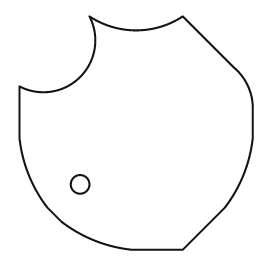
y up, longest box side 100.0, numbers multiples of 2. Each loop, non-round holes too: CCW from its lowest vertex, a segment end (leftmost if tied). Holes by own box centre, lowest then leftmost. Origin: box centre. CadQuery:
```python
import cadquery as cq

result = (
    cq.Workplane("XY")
    .moveTo(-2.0, -50.0)
    .lineTo(20.0, -50.0)
    .lineTo(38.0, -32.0)
    .threePointArc((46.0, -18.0), (50.0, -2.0))
    .lineTo(50.0, 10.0)
    .threePointArc((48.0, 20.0), (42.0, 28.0))
    .lineTo(20.0, 50.0)
    .threePointArc((0.0, 44.0), (-20.0, 50.0))
    .threePointArc((-24.0, 24.0), (-50.0, 20.0))
    .lineTo(-50.0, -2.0)
    .threePointArc((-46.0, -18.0), (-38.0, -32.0))
    .lineTo(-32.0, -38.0)
    .threePointArc((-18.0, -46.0), (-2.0, -50.0))
    .close()
    .moveTo(-24.0, -22.0)
    .circle(4.0)
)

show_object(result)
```